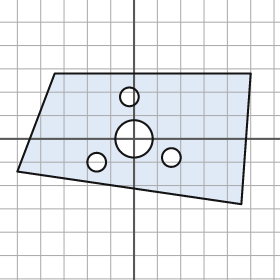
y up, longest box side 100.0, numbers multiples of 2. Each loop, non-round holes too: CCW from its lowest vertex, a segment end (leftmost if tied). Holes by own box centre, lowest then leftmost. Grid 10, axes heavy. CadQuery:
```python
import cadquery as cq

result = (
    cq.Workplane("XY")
    .moveTo(46.0, -28.0)
    .lineTo(50.0, 28.0)
    .lineTo(-34.0, 28.0)
    .lineTo(-50.0, -14.0)
    .close()
    .moveTo(-16.0, -10.0)
    .circle(4.0)
    .moveTo(16.0, -8.0)
    .circle(4.0)
    .moveTo(0.0, 0.0)
    .circle(8.0)
    .moveTo(-2.0, 18.0)
    .circle(4.0)
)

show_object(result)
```